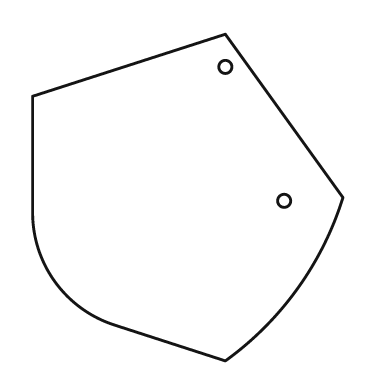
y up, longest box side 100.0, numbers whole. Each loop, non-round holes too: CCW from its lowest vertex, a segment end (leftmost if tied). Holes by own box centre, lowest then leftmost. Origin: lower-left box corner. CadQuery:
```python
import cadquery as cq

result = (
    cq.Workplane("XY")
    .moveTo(59.0, 0.0)
    .threePointArc((81.0, 22.0), (95.0, 50.0))
    .lineTo(59.0, 100.0)
    .lineTo(0.0, 81.0)
    .lineTo(0.0, 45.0)
    .threePointArc((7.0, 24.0), (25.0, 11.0))
    .close()
    .moveTo(77.0, 49.0)
    .circle(2.0)
    .moveTo(59.0, 90.0)
    .circle(2.0)
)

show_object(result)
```